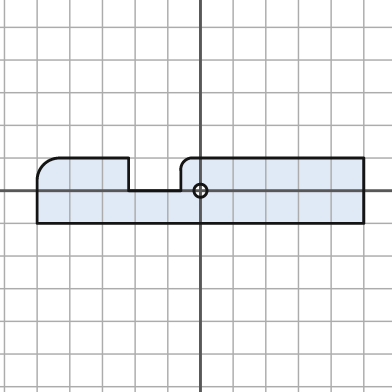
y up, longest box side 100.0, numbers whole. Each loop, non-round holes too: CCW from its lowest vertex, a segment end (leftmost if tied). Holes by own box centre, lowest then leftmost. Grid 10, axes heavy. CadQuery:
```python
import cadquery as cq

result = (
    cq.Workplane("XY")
    .moveTo(-50.0, -10.0)
    .lineTo(50.0, -10.0)
    .lineTo(50.0, 10.0)
    .lineTo(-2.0, 10.0)
    .threePointArc((-5.0, 9.0), (-6.0, 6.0))
    .lineTo(-6.0, 0.0)
    .lineTo(-22.0, 0.0)
    .lineTo(-22.0, 10.0)
    .lineTo(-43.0, 10.0)
    .threePointArc((-48.0, 8.0), (-50.0, 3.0))
    .close()
    .moveTo(0.0, 0.0)
    .circle(2.0)
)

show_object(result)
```